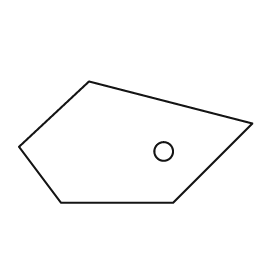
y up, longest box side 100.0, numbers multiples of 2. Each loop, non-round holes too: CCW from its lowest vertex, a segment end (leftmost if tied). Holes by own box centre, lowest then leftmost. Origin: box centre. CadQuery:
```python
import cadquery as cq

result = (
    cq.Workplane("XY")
    .moveTo(-32.0, -26.0)
    .lineTo(16.0, -26.0)
    .lineTo(50.0, 8.0)
    .lineTo(-20.0, 26.0)
    .lineTo(-50.0, -2.0)
    .close()
    .moveTo(12.0, -4.0)
    .circle(4.0)
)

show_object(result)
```